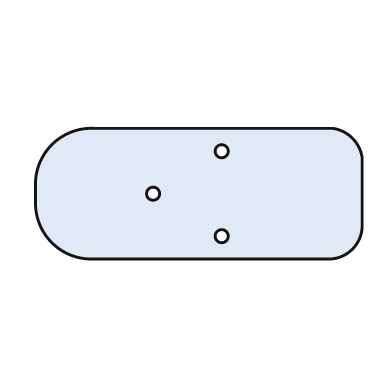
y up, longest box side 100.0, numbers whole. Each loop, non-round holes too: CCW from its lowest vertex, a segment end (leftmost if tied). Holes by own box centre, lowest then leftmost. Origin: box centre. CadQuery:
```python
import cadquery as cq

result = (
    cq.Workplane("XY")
    .moveTo(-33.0, -20.0)
    .lineTo(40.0, -20.0)
    .threePointArc((47.0, -17.0), (50.0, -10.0))
    .lineTo(50.0, 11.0)
    .threePointArc((47.0, 17.0), (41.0, 20.0))
    .lineTo(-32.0, 20.0)
    .threePointArc((-45.0, 15.0), (-50.0, 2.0))
    .lineTo(-50.0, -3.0)
    .threePointArc((-45.0, -15.0), (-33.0, -20.0))
    .close()
    .moveTo(7.0, -13.0)
    .circle(2.0)
    .moveTo(-14.0, 0.0)
    .circle(2.0)
    .moveTo(7.0, 13.0)
    .circle(2.0)
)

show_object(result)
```